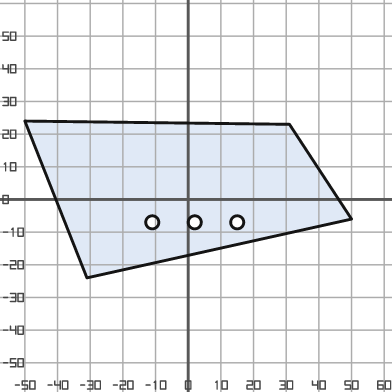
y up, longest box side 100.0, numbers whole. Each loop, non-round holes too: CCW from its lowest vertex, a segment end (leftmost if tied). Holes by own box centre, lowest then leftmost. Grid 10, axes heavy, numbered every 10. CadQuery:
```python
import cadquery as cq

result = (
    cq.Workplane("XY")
    .moveTo(-31.0, -24.0)
    .lineTo(50.0, -6.0)
    .lineTo(31.0, 23.0)
    .lineTo(-50.0, 24.0)
    .close()
    .moveTo(-11.0, -7.0)
    .circle(2.0)
    .moveTo(2.0, -7.0)
    .circle(2.0)
    .moveTo(15.0, -7.0)
    .circle(2.0)
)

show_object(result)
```